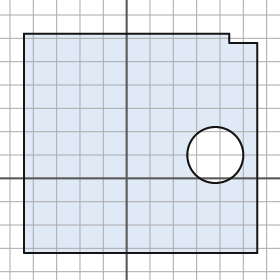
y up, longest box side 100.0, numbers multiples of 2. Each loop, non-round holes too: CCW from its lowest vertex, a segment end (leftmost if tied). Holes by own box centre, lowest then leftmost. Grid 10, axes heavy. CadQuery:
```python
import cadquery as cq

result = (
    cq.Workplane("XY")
    .moveTo(-44.0, -32.0)
    .lineTo(56.0, -32.0)
    .lineTo(56.0, 58.0)
    .lineTo(44.0, 58.0)
    .lineTo(44.0, 62.0)
    .lineTo(-44.0, 62.0)
    .close()
    .moveTo(38.0, 10.0)
    .circle(12.0)
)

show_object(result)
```